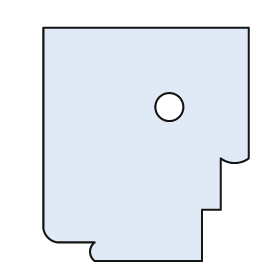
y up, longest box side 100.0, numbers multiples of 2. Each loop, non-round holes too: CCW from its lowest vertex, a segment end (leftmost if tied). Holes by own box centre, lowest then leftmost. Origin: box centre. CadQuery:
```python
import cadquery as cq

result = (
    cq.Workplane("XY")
    .moveTo(-22.0, -50.0)
    .lineTo(24.0, -50.0)
    .lineTo(24.0, -28.0)
    .lineTo(32.0, -28.0)
    .lineTo(32.0, -6.0)
    .threePointArc((38.0, -8.0), (44.0, -6.0))
    .lineTo(44.0, 50.0)
    .lineTo(-44.0, 50.0)
    .lineTo(-44.0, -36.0)
    .threePointArc((-42.0, -40.0), (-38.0, -42.0))
    .lineTo(-22.0, -42.0)
    .threePointArc((-24.0, -46.0), (-22.0, -50.0))
    .close()
    .moveTo(10.0, 16.0)
    .circle(6.0)
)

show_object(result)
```